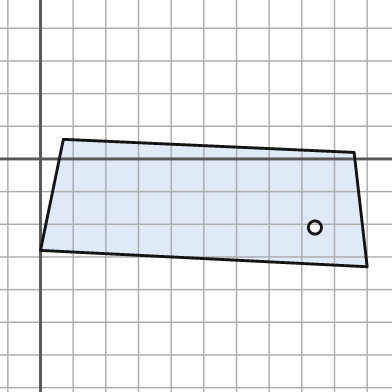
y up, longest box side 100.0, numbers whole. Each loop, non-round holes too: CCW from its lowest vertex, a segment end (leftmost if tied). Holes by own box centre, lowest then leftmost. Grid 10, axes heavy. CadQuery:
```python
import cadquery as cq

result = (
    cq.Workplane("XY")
    .moveTo(100.0, -33.0)
    .lineTo(96.0, 2.0)
    .lineTo(7.0, 6.0)
    .lineTo(0.0, -28.0)
    .close()
    .moveTo(84.0, -21.0)
    .circle(2.0)
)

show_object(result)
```